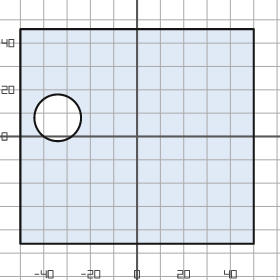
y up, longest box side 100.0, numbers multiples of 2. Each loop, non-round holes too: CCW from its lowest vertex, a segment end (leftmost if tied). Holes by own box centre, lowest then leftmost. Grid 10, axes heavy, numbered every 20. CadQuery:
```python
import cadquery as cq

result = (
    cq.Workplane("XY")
    .moveTo(-50.0, -46.0)
    .lineTo(50.0, -46.0)
    .lineTo(50.0, 46.0)
    .lineTo(-50.0, 46.0)
    .close()
    .moveTo(-34.0, 8.0)
    .circle(10.0)
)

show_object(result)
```